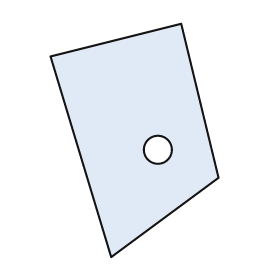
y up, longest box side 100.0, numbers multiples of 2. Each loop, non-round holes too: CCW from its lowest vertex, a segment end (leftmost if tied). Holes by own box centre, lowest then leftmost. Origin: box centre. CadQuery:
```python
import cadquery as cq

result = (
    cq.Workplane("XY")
    .moveTo(-10.0, -50.0)
    .lineTo(36.0, -16.0)
    .lineTo(20.0, 50.0)
    .lineTo(-36.0, 36.0)
    .close()
    .moveTo(10.0, -4.0)
    .circle(6.0)
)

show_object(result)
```